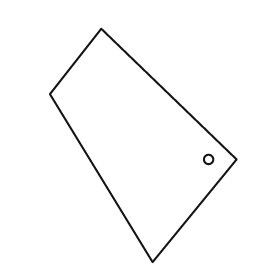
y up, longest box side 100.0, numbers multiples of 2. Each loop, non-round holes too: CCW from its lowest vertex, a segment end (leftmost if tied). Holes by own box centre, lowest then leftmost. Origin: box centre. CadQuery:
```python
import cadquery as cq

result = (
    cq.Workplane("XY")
    .moveTo(4.0, -50.0)
    .lineTo(40.0, -6.0)
    .lineTo(-18.0, 50.0)
    .lineTo(-40.0, 22.0)
    .close()
    .moveTo(28.0, -6.0)
    .circle(2.0)
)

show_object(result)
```